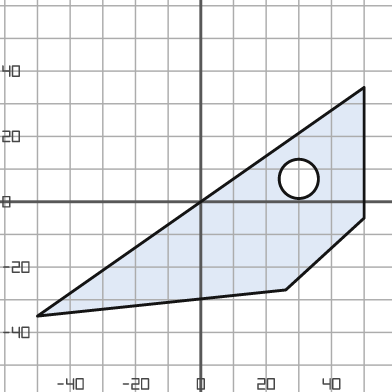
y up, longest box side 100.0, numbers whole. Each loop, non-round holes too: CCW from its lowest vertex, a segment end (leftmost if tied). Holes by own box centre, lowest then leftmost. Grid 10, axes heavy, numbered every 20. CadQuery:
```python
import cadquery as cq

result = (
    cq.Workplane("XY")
    .moveTo(-50.0, -35.0)
    .lineTo(26.0, -27.0)
    .lineTo(50.0, -5.0)
    .lineTo(50.0, 35.0)
    .close()
    .moveTo(30.0, 7.0)
    .circle(6.0)
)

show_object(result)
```